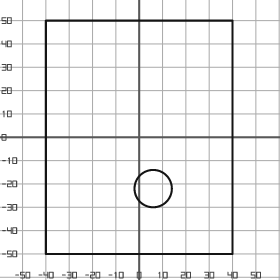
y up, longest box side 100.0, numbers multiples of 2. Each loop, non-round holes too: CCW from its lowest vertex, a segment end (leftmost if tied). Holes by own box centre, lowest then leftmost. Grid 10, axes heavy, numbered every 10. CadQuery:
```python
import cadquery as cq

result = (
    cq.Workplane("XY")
    .moveTo(-40.0, -50.0)
    .lineTo(40.0, -50.0)
    .lineTo(40.0, 50.0)
    .lineTo(-40.0, 50.0)
    .close()
    .moveTo(6.0, -22.0)
    .circle(8.0)
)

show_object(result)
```